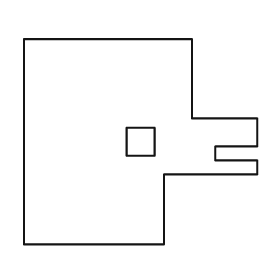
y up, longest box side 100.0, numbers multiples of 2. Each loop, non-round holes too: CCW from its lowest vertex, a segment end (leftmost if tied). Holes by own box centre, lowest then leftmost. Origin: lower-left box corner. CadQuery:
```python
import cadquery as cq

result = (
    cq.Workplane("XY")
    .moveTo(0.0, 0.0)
    .lineTo(60.0, 0.0)
    .lineTo(60.0, 30.0)
    .lineTo(100.0, 30.0)
    .lineTo(100.0, 36.0)
    .lineTo(82.0, 36.0)
    .lineTo(82.0, 42.0)
    .lineTo(100.0, 42.0)
    .lineTo(100.0, 54.0)
    .lineTo(72.0, 54.0)
    .lineTo(72.0, 88.0)
    .lineTo(0.0, 88.0)
    .close()
    .moveTo(44.0, 38.0)
    .lineTo(56.0, 38.0)
    .lineTo(56.0, 50.0)
    .lineTo(44.0, 50.0)
    .close()
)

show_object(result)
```